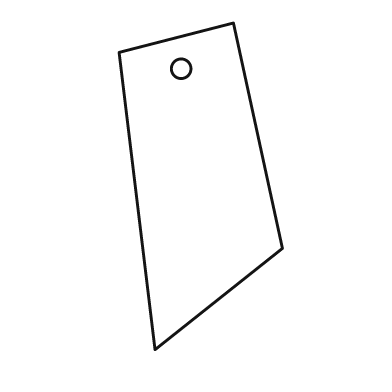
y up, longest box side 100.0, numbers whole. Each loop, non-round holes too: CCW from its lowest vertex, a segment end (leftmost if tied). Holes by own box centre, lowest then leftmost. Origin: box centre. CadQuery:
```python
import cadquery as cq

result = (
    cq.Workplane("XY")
    .moveTo(-14.0, -50.0)
    .lineTo(25.0, -19.0)
    .lineTo(10.0, 50.0)
    .lineTo(-25.0, 41.0)
    .close()
    .moveTo(-6.0, 36.0)
    .circle(3.0)
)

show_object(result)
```